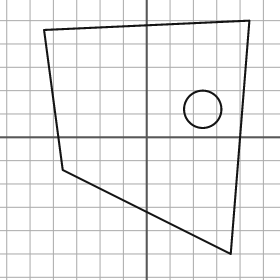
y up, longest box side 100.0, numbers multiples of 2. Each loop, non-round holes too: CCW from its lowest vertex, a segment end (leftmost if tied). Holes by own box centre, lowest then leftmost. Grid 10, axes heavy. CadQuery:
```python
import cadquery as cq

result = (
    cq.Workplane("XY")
    .moveTo(36.0, -50.0)
    .lineTo(44.0, 50.0)
    .lineTo(-44.0, 46.0)
    .lineTo(-36.0, -14.0)
    .close()
    .moveTo(24.0, 12.0)
    .circle(8.0)
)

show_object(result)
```